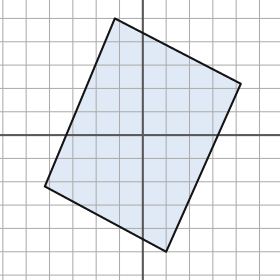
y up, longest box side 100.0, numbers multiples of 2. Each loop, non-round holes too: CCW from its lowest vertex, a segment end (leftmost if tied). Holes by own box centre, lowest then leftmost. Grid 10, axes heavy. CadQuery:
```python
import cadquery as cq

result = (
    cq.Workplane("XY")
    .moveTo(10.0, -50.0)
    .lineTo(42.0, 22.0)
    .lineTo(-12.0, 50.0)
    .lineTo(-42.0, -22.0)
    .close()
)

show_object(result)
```